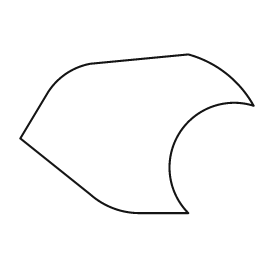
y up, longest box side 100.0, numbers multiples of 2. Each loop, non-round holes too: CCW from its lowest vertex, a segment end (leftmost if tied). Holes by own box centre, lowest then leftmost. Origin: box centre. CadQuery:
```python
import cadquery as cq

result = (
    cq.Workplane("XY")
    .moveTo(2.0, -34.0)
    .lineTo(22.0, -34.0)
    .threePointArc((18.0, 0.0), (50.0, 12.0))
    .threePointArc((38.0, 26.0), (22.0, 34.0))
    .lineTo(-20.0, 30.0)
    .threePointArc((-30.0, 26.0), (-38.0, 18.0))
    .lineTo(-50.0, -2.0)
    .lineTo(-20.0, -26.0)
    .threePointArc((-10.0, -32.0), (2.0, -34.0))
    .close()
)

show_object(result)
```